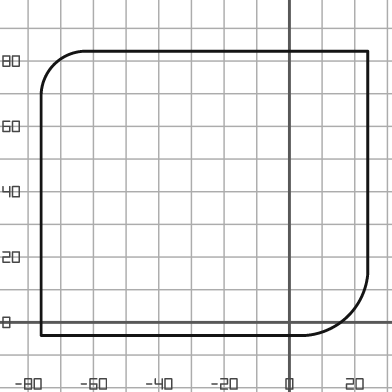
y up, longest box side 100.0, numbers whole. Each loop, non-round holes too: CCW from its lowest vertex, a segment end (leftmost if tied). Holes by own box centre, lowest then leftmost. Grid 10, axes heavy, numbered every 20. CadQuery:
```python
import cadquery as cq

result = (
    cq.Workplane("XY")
    .moveTo(-76.0, -4.0)
    .lineTo(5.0, -4.0)
    .threePointArc((18.0, 2.0), (24.0, 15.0))
    .lineTo(24.0, 83.0)
    .lineTo(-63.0, 83.0)
    .threePointArc((-72.0, 79.0), (-76.0, 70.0))
    .close()
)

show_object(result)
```